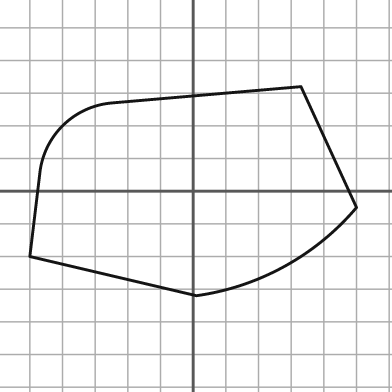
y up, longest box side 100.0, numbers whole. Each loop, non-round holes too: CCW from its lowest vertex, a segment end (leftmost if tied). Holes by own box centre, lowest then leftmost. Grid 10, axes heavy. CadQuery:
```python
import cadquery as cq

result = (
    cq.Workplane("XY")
    .moveTo(1.0, -32.0)
    .threePointArc((28.0, -23.0), (50.0, -5.0))
    .lineTo(33.0, 32.0)
    .lineTo(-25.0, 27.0)
    .threePointArc((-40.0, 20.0), (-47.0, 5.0))
    .lineTo(-50.0, -20.0)
    .close()
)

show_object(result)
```